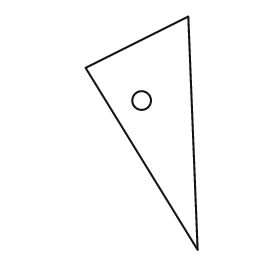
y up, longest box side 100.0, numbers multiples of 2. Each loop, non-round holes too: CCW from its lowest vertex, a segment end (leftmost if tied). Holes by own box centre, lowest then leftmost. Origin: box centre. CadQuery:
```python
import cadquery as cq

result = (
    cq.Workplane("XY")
    .moveTo(24.0, -50.0)
    .lineTo(20.0, 50.0)
    .lineTo(-24.0, 28.0)
    .close()
    .moveTo(0.0, 14.0)
    .circle(4.0)
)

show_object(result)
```